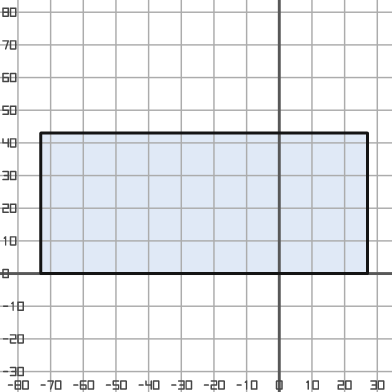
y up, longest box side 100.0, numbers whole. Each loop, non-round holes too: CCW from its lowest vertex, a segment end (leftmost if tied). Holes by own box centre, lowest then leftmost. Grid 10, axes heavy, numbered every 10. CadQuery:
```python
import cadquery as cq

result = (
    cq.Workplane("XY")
    .moveTo(-73.0, 0.0)
    .lineTo(27.0, 0.0)
    .lineTo(27.0, 43.0)
    .lineTo(-73.0, 43.0)
    .close()
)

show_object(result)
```